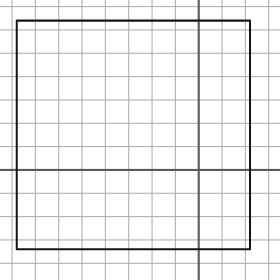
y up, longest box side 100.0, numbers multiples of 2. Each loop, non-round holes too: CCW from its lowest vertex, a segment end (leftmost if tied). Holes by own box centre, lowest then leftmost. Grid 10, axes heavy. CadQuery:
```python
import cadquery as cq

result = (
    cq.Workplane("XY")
    .moveTo(-78.0, -34.0)
    .lineTo(22.0, -34.0)
    .lineTo(22.0, 64.0)
    .lineTo(-78.0, 64.0)
    .close()
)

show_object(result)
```